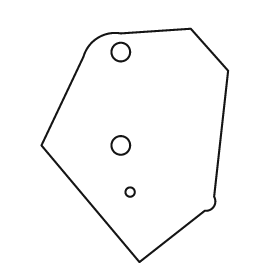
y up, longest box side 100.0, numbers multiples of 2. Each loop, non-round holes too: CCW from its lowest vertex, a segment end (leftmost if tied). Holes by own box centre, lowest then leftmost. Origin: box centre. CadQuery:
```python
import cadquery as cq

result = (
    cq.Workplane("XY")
    .moveTo(2.0, -50.0)
    .lineTo(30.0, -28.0)
    .threePointArc((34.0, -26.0), (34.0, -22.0))
    .lineTo(40.0, 32.0)
    .lineTo(24.0, 50.0)
    .lineTo(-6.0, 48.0)
    .threePointArc((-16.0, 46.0), (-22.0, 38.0))
    .lineTo(-40.0, 0.0)
    .close()
    .moveTo(-2.0, -20.0)
    .circle(2.0)
    .moveTo(-6.0, 0.0)
    .circle(4.0)
    .moveTo(-6.0, 40.0)
    .circle(4.0)
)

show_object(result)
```